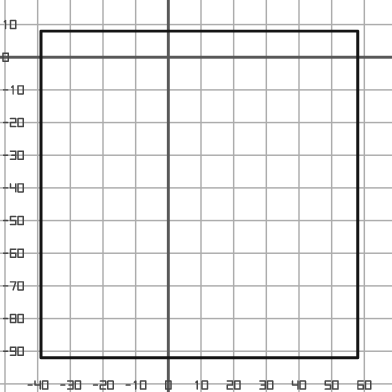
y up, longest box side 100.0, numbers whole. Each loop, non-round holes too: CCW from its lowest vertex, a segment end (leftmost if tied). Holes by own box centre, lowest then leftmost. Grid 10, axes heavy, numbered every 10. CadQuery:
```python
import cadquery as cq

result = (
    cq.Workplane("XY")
    .moveTo(-39.0, -92.0)
    .lineTo(58.0, -92.0)
    .lineTo(58.0, 8.0)
    .lineTo(-39.0, 8.0)
    .close()
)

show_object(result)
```